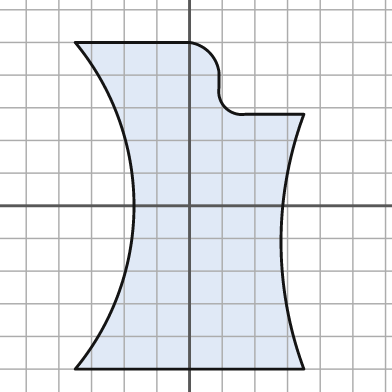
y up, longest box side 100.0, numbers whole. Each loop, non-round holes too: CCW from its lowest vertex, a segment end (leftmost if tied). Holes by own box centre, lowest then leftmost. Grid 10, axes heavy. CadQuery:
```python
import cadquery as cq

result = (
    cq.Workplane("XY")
    .moveTo(-35.0, -50.0)
    .lineTo(35.0, -50.0)
    .threePointArc((28.0, -11.0), (35.0, 28.0))
    .lineTo(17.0, 28.0)
    .threePointArc((11.0, 30.0), (9.0, 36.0))
    .lineTo(9.0, 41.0)
    .threePointArc((6.0, 47.0), (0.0, 50.0))
    .lineTo(-35.0, 50.0)
    .threePointArc((-17.0, 0.0), (-35.0, -50.0))
    .close()
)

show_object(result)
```